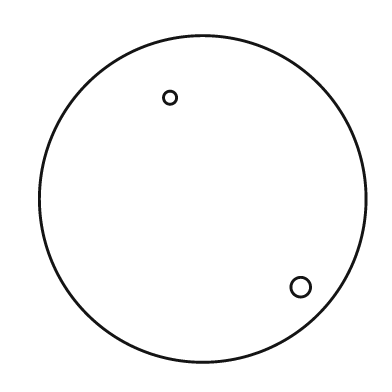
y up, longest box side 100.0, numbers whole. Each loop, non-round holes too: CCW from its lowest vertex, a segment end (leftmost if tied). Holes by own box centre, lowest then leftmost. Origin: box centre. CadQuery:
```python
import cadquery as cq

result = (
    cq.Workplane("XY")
    .moveTo(0.0, 0.0)
    .circle(50.0)
    .moveTo(30.0, -27.0)
    .circle(3.0)
    .moveTo(-10.0, 31.0)
    .circle(2.0)
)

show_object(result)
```